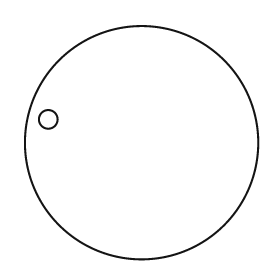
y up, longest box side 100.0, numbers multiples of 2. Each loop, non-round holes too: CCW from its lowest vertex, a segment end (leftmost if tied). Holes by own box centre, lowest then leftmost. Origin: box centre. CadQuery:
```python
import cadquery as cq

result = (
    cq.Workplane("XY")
    .moveTo(0.0, 0.0)
    .circle(50.0)
    .moveTo(-40.0, 10.0)
    .circle(4.0)
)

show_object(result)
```